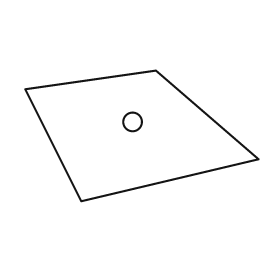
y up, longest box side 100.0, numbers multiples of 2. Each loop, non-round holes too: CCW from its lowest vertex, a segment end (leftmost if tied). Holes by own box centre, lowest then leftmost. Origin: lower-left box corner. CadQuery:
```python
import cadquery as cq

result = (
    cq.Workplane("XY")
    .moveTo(24.0, 0.0)
    .lineTo(100.0, 18.0)
    .lineTo(56.0, 56.0)
    .lineTo(0.0, 48.0)
    .close()
    .moveTo(46.0, 34.0)
    .circle(4.0)
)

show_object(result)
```